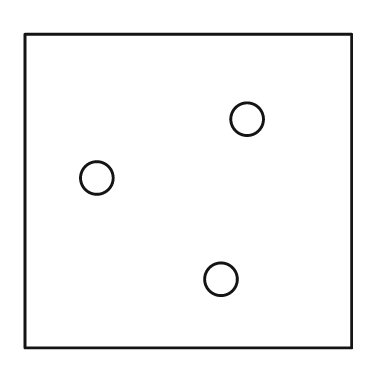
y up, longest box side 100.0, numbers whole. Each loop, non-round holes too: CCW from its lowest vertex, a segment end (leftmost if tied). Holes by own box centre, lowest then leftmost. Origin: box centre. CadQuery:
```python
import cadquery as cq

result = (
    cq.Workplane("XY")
    .moveTo(-50.0, -48.0)
    .lineTo(50.0, -48.0)
    .lineTo(50.0, 48.0)
    .lineTo(-50.0, 48.0)
    .close()
    .moveTo(10.0, -27.0)
    .circle(5.0)
    .moveTo(-28.0, 4.0)
    .circle(5.0)
    .moveTo(18.0, 22.0)
    .circle(5.0)
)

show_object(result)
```